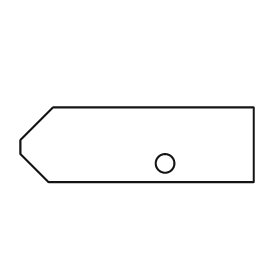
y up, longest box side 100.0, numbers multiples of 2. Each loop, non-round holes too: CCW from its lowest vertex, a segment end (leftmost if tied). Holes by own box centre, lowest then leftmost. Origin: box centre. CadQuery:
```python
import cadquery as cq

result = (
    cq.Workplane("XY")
    .moveTo(-38.0, -16.0)
    .lineTo(50.0, -16.0)
    .lineTo(50.0, 16.0)
    .lineTo(-36.0, 16.0)
    .lineTo(-50.0, 2.0)
    .lineTo(-50.0, -4.0)
    .close()
    .moveTo(12.0, -8.0)
    .circle(4.0)
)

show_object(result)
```